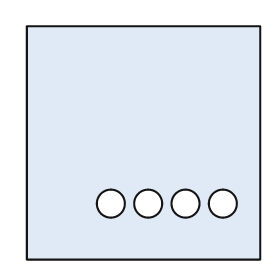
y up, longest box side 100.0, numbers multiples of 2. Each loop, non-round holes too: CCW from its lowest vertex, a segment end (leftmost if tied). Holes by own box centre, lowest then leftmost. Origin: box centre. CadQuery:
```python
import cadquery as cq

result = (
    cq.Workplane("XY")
    .moveTo(-50.0, -50.0)
    .lineTo(50.0, -50.0)
    .lineTo(50.0, 50.0)
    .lineTo(-50.0, 50.0)
    .close()
    .moveTo(-14.0, -26.0)
    .circle(6.0)
    .moveTo(2.0, -26.0)
    .circle(6.0)
    .moveTo(18.0, -26.0)
    .circle(6.0)
    .moveTo(34.0, -26.0)
    .circle(6.0)
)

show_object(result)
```